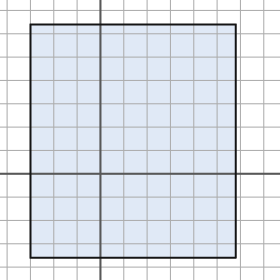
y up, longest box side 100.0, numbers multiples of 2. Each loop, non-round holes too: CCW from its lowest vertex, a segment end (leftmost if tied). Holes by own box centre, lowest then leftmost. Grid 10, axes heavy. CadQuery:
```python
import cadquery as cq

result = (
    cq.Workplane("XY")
    .moveTo(-30.0, -36.0)
    .lineTo(58.0, -36.0)
    .lineTo(58.0, 64.0)
    .lineTo(-30.0, 64.0)
    .close()
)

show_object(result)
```